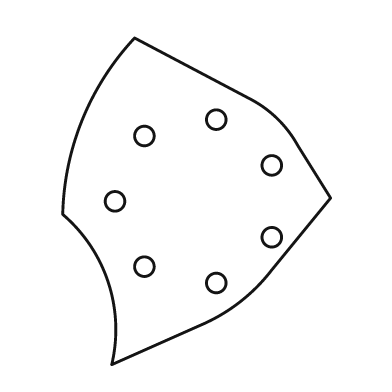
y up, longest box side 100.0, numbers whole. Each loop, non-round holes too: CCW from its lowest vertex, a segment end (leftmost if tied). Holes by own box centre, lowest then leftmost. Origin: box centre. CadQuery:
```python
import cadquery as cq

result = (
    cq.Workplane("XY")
    .moveTo(-26.0, -50.0)
    .lineTo(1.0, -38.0)
    .threePointArc((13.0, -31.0), (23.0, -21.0))
    .lineTo(41.0, 1.0)
    .lineTo(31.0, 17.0)
    .threePointArc((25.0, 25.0), (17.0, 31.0))
    .lineTo(-19.0, 50.0)
    .threePointArc((-35.0, 25.0), (-41.0, -4.0))
    .threePointArc((-27.0, -25.0), (-26.0, -50.0))
    .close()
    .moveTo(6.0, -25.0)
    .circle(3.0)
    .moveTo(-16.0, -20.0)
    .circle(3.0)
    .moveTo(23.0, -11.0)
    .circle(3.0)
    .moveTo(-25.0, 0.0)
    .circle(3.0)
    .moveTo(23.0, 11.0)
    .circle(3.0)
    .moveTo(-16.0, 20.0)
    .circle(3.0)
    .moveTo(6.0, 25.0)
    .circle(3.0)
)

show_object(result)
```